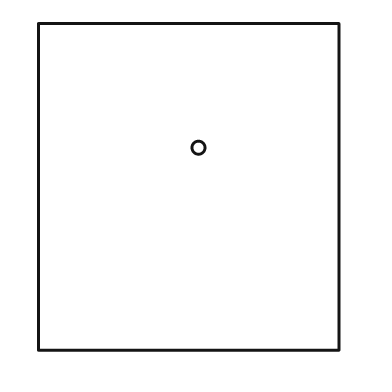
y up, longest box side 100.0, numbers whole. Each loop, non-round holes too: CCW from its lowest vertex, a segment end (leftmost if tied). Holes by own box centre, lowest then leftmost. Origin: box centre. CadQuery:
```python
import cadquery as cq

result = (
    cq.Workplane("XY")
    .moveTo(-46.0, -50.0)
    .lineTo(46.0, -50.0)
    .lineTo(46.0, 50.0)
    .lineTo(-46.0, 50.0)
    .close()
    .moveTo(3.0, 12.0)
    .circle(2.0)
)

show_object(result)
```